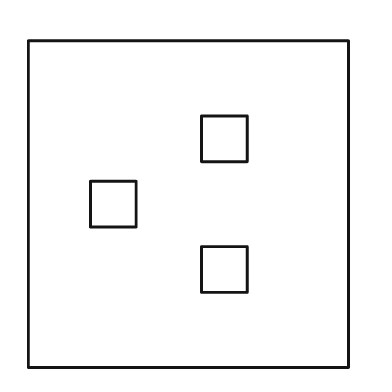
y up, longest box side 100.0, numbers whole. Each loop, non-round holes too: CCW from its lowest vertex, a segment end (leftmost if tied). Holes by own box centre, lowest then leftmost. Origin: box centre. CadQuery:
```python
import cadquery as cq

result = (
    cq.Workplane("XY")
    .moveTo(-49.0, -50.0)
    .lineTo(49.0, -50.0)
    .lineTo(49.0, 50.0)
    .lineTo(-49.0, 50.0)
    .close()
    .moveTo(4.0, -27.0)
    .lineTo(18.0, -27.0)
    .lineTo(18.0, -13.0)
    .lineTo(4.0, -13.0)
    .close()
    .moveTo(-30.0, -7.0)
    .lineTo(-16.0, -7.0)
    .lineTo(-16.0, 7.0)
    .lineTo(-30.0, 7.0)
    .close()
    .moveTo(4.0, 13.0)
    .lineTo(18.0, 13.0)
    .lineTo(18.0, 27.0)
    .lineTo(4.0, 27.0)
    .close()
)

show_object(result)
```